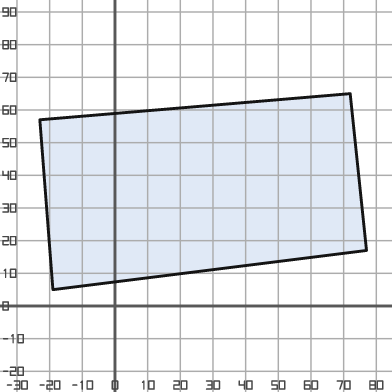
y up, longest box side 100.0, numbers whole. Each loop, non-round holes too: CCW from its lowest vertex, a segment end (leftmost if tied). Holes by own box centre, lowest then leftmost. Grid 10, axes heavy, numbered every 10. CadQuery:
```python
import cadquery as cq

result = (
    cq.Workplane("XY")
    .moveTo(-19.0, 5.0)
    .lineTo(77.0, 17.0)
    .lineTo(72.0, 65.0)
    .lineTo(-23.0, 57.0)
    .close()
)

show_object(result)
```